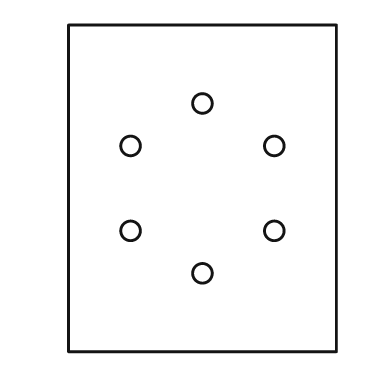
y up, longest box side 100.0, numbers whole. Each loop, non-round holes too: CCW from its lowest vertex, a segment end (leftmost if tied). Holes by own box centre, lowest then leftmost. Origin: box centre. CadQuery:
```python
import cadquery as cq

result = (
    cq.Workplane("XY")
    .moveTo(-41.0, -50.0)
    .lineTo(41.0, -50.0)
    .lineTo(41.0, 50.0)
    .lineTo(-41.0, 50.0)
    .close()
    .moveTo(0.0, -26.0)
    .circle(3.0)
    .moveTo(-22.0, -13.0)
    .circle(3.0)
    .moveTo(22.0, -13.0)
    .circle(3.0)
    .moveTo(-22.0, 13.0)
    .circle(3.0)
    .moveTo(22.0, 13.0)
    .circle(3.0)
    .moveTo(0.0, 26.0)
    .circle(3.0)
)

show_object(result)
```